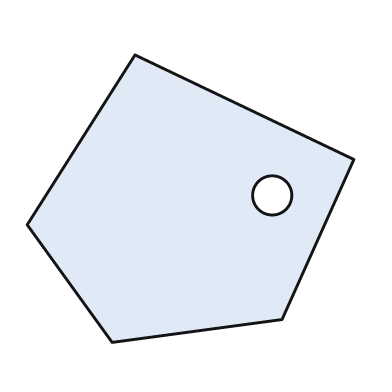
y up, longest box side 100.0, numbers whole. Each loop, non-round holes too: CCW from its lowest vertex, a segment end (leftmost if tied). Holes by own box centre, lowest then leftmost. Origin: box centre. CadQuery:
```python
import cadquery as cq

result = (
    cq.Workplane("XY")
    .moveTo(-24.0, -44.0)
    .lineTo(28.0, -37.0)
    .lineTo(50.0, 12.0)
    .lineTo(-17.0, 44.0)
    .lineTo(-50.0, -8.0)
    .close()
    .moveTo(25.0, 1.0)
    .circle(6.0)
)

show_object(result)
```